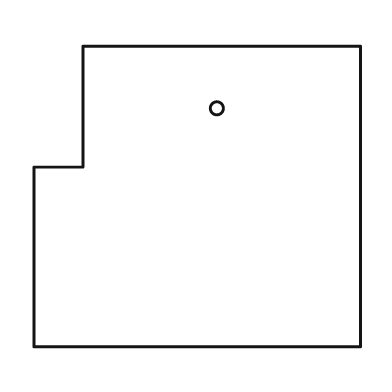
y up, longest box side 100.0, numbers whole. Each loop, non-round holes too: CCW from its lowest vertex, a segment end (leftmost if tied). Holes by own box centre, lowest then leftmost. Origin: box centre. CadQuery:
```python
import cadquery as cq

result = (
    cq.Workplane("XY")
    .moveTo(-50.0, -46.0)
    .lineTo(50.0, -46.0)
    .lineTo(50.0, 46.0)
    .lineTo(-35.0, 46.0)
    .lineTo(-35.0, 9.0)
    .lineTo(-50.0, 9.0)
    .close()
    .moveTo(6.0, 27.0)
    .circle(2.0)
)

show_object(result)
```